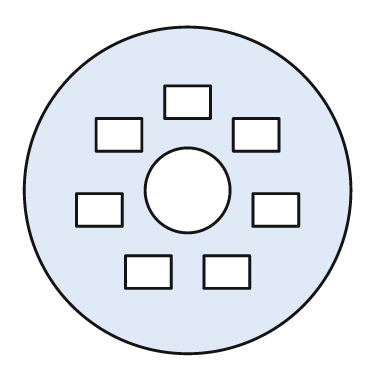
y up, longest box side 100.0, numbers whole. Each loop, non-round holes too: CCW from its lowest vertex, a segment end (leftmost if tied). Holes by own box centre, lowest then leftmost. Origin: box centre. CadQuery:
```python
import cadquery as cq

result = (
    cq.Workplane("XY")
    .moveTo(0.0, 0.0)
    .circle(50.0)
    .moveTo(-19.0, -30.0)
    .lineTo(-5.0, -30.0)
    .lineTo(-5.0, -20.0)
    .lineTo(-19.0, -20.0)
    .close()
    .moveTo(5.0, -30.0)
    .lineTo(19.0, -30.0)
    .lineTo(19.0, -20.0)
    .lineTo(5.0, -20.0)
    .close()
    .moveTo(-34.0, -11.0)
    .lineTo(-20.0, -11.0)
    .lineTo(-20.0, -1.0)
    .lineTo(-34.0, -1.0)
    .close()
    .moveTo(20.0, -11.0)
    .lineTo(34.0, -11.0)
    .lineTo(34.0, -1.0)
    .lineTo(20.0, -1.0)
    .close()
    .moveTo(0.0, 0.0)
    .circle(13.0)
    .moveTo(-28.0, 12.0)
    .lineTo(-14.0, 12.0)
    .lineTo(-14.0, 22.0)
    .lineTo(-28.0, 22.0)
    .close()
    .moveTo(14.0, 12.0)
    .lineTo(28.0, 12.0)
    .lineTo(28.0, 22.0)
    .lineTo(14.0, 22.0)
    .close()
    .moveTo(-7.0, 22.0)
    .lineTo(7.0, 22.0)
    .lineTo(7.0, 32.0)
    .lineTo(-7.0, 32.0)
    .close()
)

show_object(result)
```